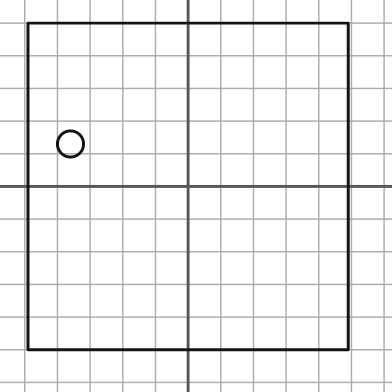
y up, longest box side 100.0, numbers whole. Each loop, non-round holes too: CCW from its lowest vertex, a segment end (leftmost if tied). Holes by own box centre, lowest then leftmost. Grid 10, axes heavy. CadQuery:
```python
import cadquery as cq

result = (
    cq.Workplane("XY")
    .moveTo(-49.0, -50.0)
    .lineTo(49.0, -50.0)
    .lineTo(49.0, 50.0)
    .lineTo(-49.0, 50.0)
    .close()
    .moveTo(-36.0, 13.0)
    .circle(4.0)
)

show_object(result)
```